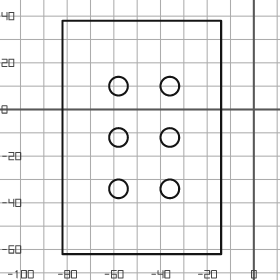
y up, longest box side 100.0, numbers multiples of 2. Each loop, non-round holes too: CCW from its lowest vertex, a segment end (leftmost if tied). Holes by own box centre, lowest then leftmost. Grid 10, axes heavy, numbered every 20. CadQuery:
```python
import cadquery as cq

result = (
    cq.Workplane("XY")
    .moveTo(-82.0, -62.0)
    .lineTo(-14.0, -62.0)
    .lineTo(-14.0, 38.0)
    .lineTo(-82.0, 38.0)
    .close()
    .moveTo(-58.0, -34.0)
    .circle(4.0)
    .moveTo(-36.0, -34.0)
    .circle(4.0)
    .moveTo(-58.0, -12.0)
    .circle(4.0)
    .moveTo(-36.0, -12.0)
    .circle(4.0)
    .moveTo(-58.0, 10.0)
    .circle(4.0)
    .moveTo(-36.0, 10.0)
    .circle(4.0)
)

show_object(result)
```